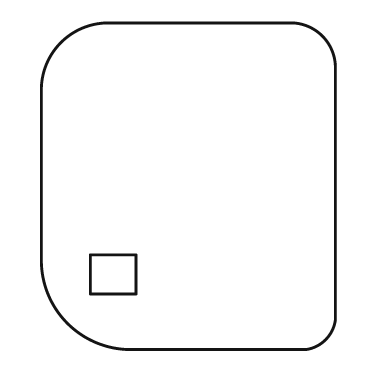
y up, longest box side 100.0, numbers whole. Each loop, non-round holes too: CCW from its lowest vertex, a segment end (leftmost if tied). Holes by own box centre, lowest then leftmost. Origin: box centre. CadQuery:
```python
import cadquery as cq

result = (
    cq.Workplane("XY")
    .moveTo(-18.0, -50.0)
    .lineTo(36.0, -50.0)
    .threePointArc((42.0, -47.0), (45.0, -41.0))
    .lineTo(45.0, 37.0)
    .threePointArc((41.0, 46.0), (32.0, 50.0))
    .lineTo(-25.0, 50.0)
    .threePointArc((-39.0, 44.0), (-45.0, 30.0))
    .lineTo(-45.0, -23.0)
    .threePointArc((-37.0, -42.0), (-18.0, -50.0))
    .close()
    .moveTo(-30.0, -33.0)
    .lineTo(-16.0, -33.0)
    .lineTo(-16.0, -21.0)
    .lineTo(-30.0, -21.0)
    .close()
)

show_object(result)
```